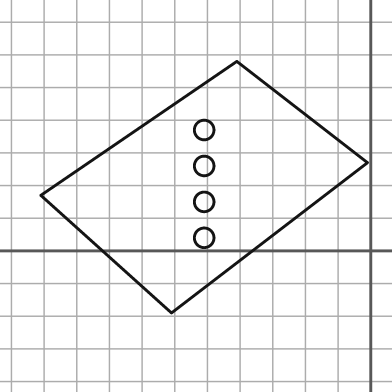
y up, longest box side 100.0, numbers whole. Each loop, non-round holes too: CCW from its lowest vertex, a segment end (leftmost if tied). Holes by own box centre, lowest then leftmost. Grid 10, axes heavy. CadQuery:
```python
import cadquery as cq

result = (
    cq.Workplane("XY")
    .moveTo(-61.0, -19.0)
    .lineTo(-1.0, 27.0)
    .lineTo(-41.0, 58.0)
    .lineTo(-101.0, 17.0)
    .close()
    .moveTo(-51.0, 4.0)
    .circle(3.0)
    .moveTo(-51.0, 15.0)
    .circle(3.0)
    .moveTo(-51.0, 26.0)
    .circle(3.0)
    .moveTo(-51.0, 37.0)
    .circle(3.0)
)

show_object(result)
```